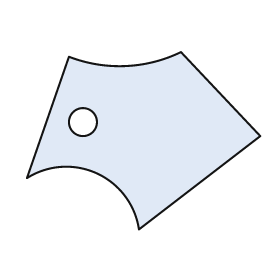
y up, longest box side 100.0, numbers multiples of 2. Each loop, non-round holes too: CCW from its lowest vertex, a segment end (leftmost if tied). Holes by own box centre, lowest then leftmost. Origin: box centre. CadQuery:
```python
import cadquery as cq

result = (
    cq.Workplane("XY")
    .moveTo(-2.0, -38.0)
    .lineTo(50.0, 2.0)
    .lineTo(16.0, 38.0)
    .threePointArc((-8.0, 32.0), (-32.0, 36.0))
    .lineTo(-50.0, -16.0)
    .threePointArc((-20.0, -14.0), (-2.0, -38.0))
    .close()
    .moveTo(-26.0, 8.0)
    .circle(6.0)
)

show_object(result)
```